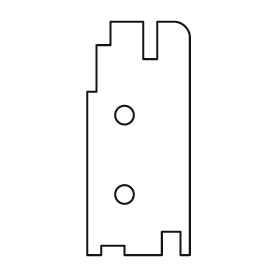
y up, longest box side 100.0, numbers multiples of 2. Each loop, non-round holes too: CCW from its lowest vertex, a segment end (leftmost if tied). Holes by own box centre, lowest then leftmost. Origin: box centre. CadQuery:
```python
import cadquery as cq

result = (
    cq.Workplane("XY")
    .moveTo(-22.0, -50.0)
    .lineTo(-16.0, -50.0)
    .lineTo(-16.0, -46.0)
    .lineTo(-6.0, -46.0)
    .lineTo(-6.0, -50.0)
    .lineTo(10.0, -50.0)
    .lineTo(10.0, -40.0)
    .lineTo(18.0, -40.0)
    .lineTo(18.0, -50.0)
    .lineTo(22.0, -50.0)
    .lineTo(22.0, 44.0)
    .threePointArc((20.0, 48.0), (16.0, 50.0))
    .lineTo(8.0, 50.0)
    .lineTo(8.0, 34.0)
    .lineTo(2.0, 34.0)
    .lineTo(2.0, 50.0)
    .lineTo(-12.0, 50.0)
    .lineTo(-12.0, 40.0)
    .lineTo(-18.0, 40.0)
    .lineTo(-18.0, 20.0)
    .lineTo(-22.0, 20.0)
    .close()
    .moveTo(-6.0, -24.0)
    .circle(4.0)
    .moveTo(-6.0, 10.0)
    .circle(4.0)
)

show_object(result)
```